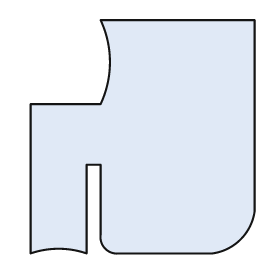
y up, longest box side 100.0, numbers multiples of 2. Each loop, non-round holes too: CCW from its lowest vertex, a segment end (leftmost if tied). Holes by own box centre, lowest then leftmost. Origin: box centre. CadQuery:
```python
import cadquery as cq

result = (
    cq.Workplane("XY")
    .moveTo(-48.0, -50.0)
    .threePointArc((-36.0, -48.0), (-24.0, -50.0))
    .lineTo(-24.0, -12.0)
    .lineTo(-18.0, -12.0)
    .lineTo(-18.0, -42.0)
    .threePointArc((-16.0, -48.0), (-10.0, -50.0))
    .lineTo(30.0, -50.0)
    .threePointArc((42.0, -44.0), (48.0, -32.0))
    .lineTo(48.0, 50.0)
    .lineTo(-18.0, 50.0)
    .threePointArc((-14.0, 32.0), (-18.0, 14.0))
    .lineTo(-48.0, 14.0)
    .close()
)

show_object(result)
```